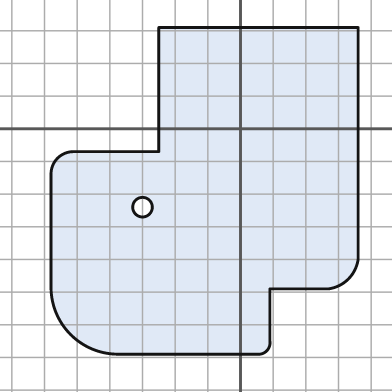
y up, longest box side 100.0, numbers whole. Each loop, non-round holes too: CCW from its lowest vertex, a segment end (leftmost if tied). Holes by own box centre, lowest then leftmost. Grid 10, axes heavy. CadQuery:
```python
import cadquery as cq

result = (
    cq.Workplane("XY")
    .moveTo(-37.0, -69.0)
    .lineTo(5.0, -69.0)
    .threePointArc((8.0, -68.0), (9.0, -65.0))
    .lineTo(9.0, -49.0)
    .lineTo(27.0, -49.0)
    .threePointArc((33.0, -46.0), (36.0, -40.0))
    .lineTo(36.0, 31.0)
    .lineTo(-25.0, 31.0)
    .lineTo(-25.0, -7.0)
    .lineTo(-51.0, -7.0)
    .threePointArc((-56.0, -9.0), (-58.0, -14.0))
    .lineTo(-58.0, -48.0)
    .threePointArc((-52.0, -63.0), (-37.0, -69.0))
    .close()
    .moveTo(-30.0, -24.0)
    .circle(3.0)
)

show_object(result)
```